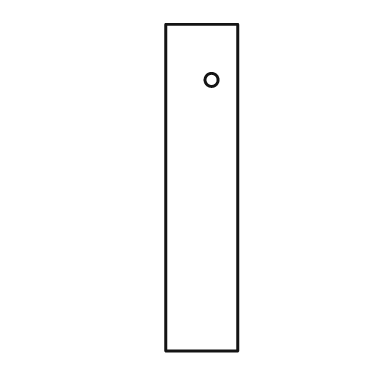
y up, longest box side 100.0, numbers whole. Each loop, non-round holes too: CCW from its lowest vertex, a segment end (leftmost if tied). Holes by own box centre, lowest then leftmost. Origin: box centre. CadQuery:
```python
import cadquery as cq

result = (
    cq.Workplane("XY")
    .moveTo(-11.0, -50.0)
    .lineTo(11.0, -50.0)
    .lineTo(11.0, 50.0)
    .lineTo(-11.0, 50.0)
    .close()
    .moveTo(3.0, 33.0)
    .circle(2.0)
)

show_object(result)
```